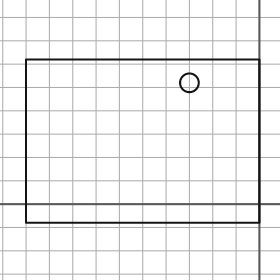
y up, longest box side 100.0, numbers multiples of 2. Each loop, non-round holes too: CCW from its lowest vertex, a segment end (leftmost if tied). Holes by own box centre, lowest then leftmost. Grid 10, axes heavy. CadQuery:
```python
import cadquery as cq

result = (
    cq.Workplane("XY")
    .moveTo(-100.0, -8.0)
    .lineTo(0.0, -8.0)
    .lineTo(0.0, 62.0)
    .lineTo(-100.0, 62.0)
    .close()
    .moveTo(-30.0, 52.0)
    .circle(4.0)
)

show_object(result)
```